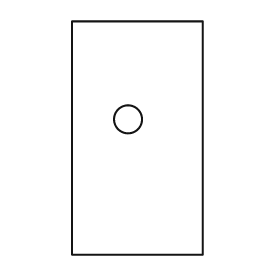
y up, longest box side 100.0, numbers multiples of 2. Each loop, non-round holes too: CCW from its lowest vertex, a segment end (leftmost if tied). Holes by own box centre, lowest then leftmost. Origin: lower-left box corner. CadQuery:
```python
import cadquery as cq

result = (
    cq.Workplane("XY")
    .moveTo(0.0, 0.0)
    .lineTo(56.0, 0.0)
    .lineTo(56.0, 100.0)
    .lineTo(0.0, 100.0)
    .close()
    .moveTo(24.0, 58.0)
    .circle(6.0)
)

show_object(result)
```